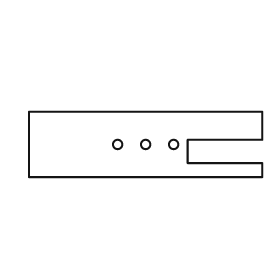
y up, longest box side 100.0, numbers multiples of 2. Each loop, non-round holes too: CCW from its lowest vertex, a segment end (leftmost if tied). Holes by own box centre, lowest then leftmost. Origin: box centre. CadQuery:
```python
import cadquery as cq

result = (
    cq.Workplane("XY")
    .moveTo(-50.0, -14.0)
    .lineTo(50.0, -14.0)
    .lineTo(50.0, -8.0)
    .lineTo(18.0, -8.0)
    .lineTo(18.0, 2.0)
    .lineTo(50.0, 2.0)
    .lineTo(50.0, 14.0)
    .lineTo(-50.0, 14.0)
    .close()
    .moveTo(-12.0, 0.0)
    .circle(2.0)
    .moveTo(0.0, 0.0)
    .circle(2.0)
    .moveTo(12.0, 0.0)
    .circle(2.0)
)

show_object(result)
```